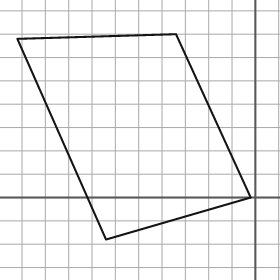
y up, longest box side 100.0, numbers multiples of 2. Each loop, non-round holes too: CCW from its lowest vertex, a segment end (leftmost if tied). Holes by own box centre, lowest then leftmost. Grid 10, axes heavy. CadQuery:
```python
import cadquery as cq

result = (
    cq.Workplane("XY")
    .moveTo(-64.0, -18.0)
    .lineTo(-2.0, 0.0)
    .lineTo(-34.0, 70.0)
    .lineTo(-102.0, 68.0)
    .close()
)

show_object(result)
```